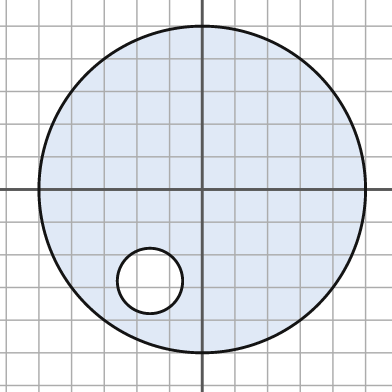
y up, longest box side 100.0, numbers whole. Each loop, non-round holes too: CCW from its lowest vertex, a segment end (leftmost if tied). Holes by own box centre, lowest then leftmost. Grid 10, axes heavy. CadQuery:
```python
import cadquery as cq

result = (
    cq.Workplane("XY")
    .moveTo(0.0, 0.0)
    .circle(50.0)
    .moveTo(-16.0, -28.0)
    .circle(10.0)
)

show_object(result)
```